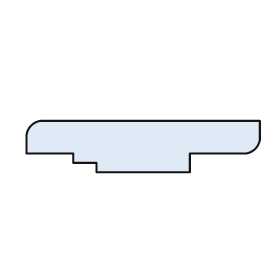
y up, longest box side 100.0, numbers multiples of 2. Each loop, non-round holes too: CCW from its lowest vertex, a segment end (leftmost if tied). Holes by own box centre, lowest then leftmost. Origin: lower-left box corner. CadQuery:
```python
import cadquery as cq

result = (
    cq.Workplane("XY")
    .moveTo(30.0, 0.0)
    .lineTo(70.0, 0.0)
    .lineTo(70.0, 8.0)
    .lineTo(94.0, 8.0)
    .threePointArc((98.0, 10.0), (100.0, 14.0))
    .lineTo(100.0, 22.0)
    .lineTo(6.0, 22.0)
    .threePointArc((2.0, 20.0), (0.0, 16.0))
    .lineTo(0.0, 8.0)
    .lineTo(20.0, 8.0)
    .lineTo(20.0, 4.0)
    .lineTo(30.0, 4.0)
    .close()
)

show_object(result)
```